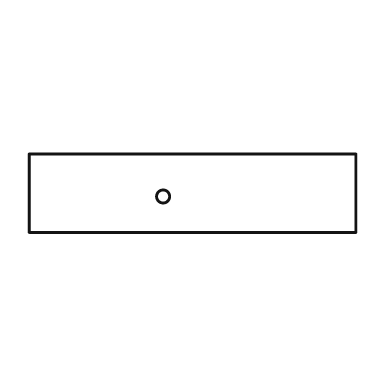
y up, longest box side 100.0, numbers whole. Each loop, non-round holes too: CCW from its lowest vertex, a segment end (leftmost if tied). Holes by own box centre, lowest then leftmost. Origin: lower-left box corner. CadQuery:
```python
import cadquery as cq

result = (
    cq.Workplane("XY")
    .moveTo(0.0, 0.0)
    .lineTo(100.0, 0.0)
    .lineTo(100.0, 24.0)
    .lineTo(0.0, 24.0)
    .close()
    .moveTo(41.0, 11.0)
    .circle(2.0)
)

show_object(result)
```